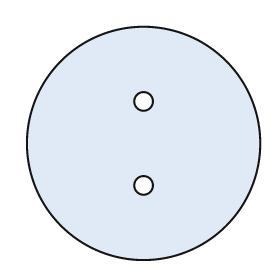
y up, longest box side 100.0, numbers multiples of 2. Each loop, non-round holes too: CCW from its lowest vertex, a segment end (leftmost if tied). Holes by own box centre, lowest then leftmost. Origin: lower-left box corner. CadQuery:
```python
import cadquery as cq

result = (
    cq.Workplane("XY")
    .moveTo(50.0, 50.0)
    .circle(50.0)
    .moveTo(50.0, 32.0)
    .circle(4.0)
    .moveTo(50.0, 68.0)
    .circle(4.0)
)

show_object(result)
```